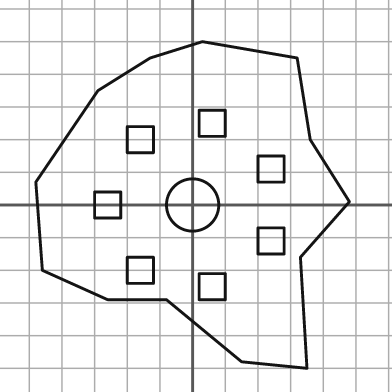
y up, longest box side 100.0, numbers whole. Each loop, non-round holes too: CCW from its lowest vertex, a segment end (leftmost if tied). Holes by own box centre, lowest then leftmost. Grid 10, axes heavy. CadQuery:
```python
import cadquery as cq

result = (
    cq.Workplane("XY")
    .moveTo(35.0, -50.0)
    .lineTo(33.0, -16.0)
    .lineTo(48.0, 1.0)
    .lineTo(36.0, 20.0)
    .lineTo(32.0, 45.0)
    .lineTo(3.0, 50.0)
    .lineTo(-13.0, 45.0)
    .lineTo(-29.0, 35.0)
    .lineTo(-48.0, 7.0)
    .lineTo(-46.0, -20.0)
    .lineTo(-26.0, -29.0)
    .lineTo(-8.0, -29.0)
    .lineTo(15.0, -48.0)
    .close()
    .moveTo(2.0, -29.0)
    .lineTo(10.0, -29.0)
    .lineTo(10.0, -21.0)
    .lineTo(2.0, -21.0)
    .close()
    .moveTo(-20.0, -24.0)
    .lineTo(-12.0, -24.0)
    .lineTo(-12.0, -16.0)
    .lineTo(-20.0, -16.0)
    .close()
    .moveTo(20.0, -15.0)
    .lineTo(28.0, -15.0)
    .lineTo(28.0, -7.0)
    .lineTo(20.0, -7.0)
    .close()
    .moveTo(-30.0, -4.0)
    .lineTo(-22.0, -4.0)
    .lineTo(-22.0, 4.0)
    .lineTo(-30.0, 4.0)
    .close()
    .moveTo(0.0, 0.0)
    .circle(8.0)
    .moveTo(20.0, 7.0)
    .lineTo(28.0, 7.0)
    .lineTo(28.0, 15.0)
    .lineTo(20.0, 15.0)
    .close()
    .moveTo(-20.0, 16.0)
    .lineTo(-12.0, 16.0)
    .lineTo(-12.0, 24.0)
    .lineTo(-20.0, 24.0)
    .close()
    .moveTo(2.0, 21.0)
    .lineTo(10.0, 21.0)
    .lineTo(10.0, 29.0)
    .lineTo(2.0, 29.0)
    .close()
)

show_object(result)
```